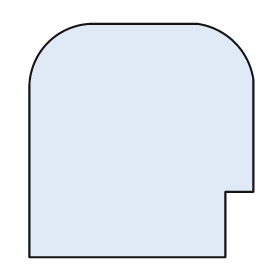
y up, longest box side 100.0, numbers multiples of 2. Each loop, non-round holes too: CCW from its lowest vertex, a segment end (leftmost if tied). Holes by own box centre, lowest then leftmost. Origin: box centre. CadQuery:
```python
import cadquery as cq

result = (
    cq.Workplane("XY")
    .moveTo(-48.0, -50.0)
    .lineTo(36.0, -50.0)
    .lineTo(36.0, -22.0)
    .lineTo(48.0, -22.0)
    .lineTo(48.0, 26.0)
    .threePointArc((40.0, 42.0), (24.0, 50.0))
    .lineTo(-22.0, 50.0)
    .threePointArc((-40.0, 42.0), (-48.0, 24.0))
    .close()
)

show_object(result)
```